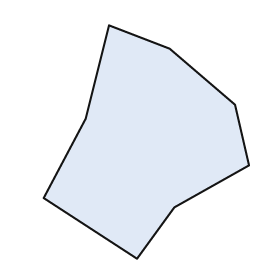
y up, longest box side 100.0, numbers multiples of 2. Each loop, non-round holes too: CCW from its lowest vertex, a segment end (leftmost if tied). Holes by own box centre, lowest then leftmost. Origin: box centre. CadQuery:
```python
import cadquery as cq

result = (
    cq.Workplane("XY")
    .moveTo(-4.0, -50.0)
    .lineTo(12.0, -28.0)
    .lineTo(44.0, -10.0)
    .lineTo(38.0, 16.0)
    .lineTo(10.0, 40.0)
    .lineTo(-16.0, 50.0)
    .lineTo(-26.0, 10.0)
    .lineTo(-44.0, -24.0)
    .close()
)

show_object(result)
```